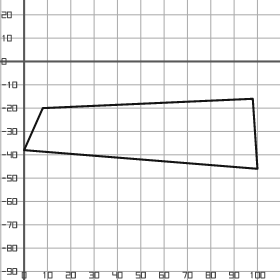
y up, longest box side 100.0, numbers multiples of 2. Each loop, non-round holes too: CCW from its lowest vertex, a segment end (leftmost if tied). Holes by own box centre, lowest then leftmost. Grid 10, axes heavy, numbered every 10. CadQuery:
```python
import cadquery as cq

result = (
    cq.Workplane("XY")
    .moveTo(100.0, -46.0)
    .lineTo(98.0, -16.0)
    .lineTo(8.0, -20.0)
    .lineTo(0.0, -38.0)
    .close()
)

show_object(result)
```